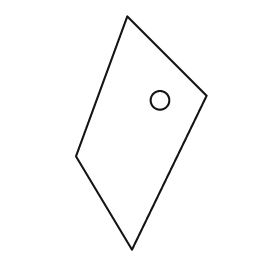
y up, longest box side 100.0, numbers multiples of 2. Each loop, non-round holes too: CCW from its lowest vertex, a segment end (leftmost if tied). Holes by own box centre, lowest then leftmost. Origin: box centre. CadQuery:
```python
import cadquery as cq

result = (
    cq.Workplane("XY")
    .moveTo(-4.0, -50.0)
    .lineTo(28.0, 16.0)
    .lineTo(-6.0, 50.0)
    .lineTo(-28.0, -10.0)
    .close()
    .moveTo(8.0, 14.0)
    .circle(4.0)
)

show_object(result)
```